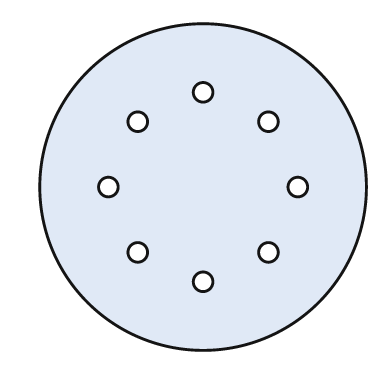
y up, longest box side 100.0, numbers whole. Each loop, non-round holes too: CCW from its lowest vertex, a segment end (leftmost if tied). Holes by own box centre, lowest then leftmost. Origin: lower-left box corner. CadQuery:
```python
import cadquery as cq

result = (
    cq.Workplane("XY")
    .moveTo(50.0, 50.0)
    .circle(50.0)
    .moveTo(50.0, 21.0)
    .circle(3.0)
    .moveTo(30.0, 30.0)
    .circle(3.0)
    .moveTo(70.0, 30.0)
    .circle(3.0)
    .moveTo(21.0, 50.0)
    .circle(3.0)
    .moveTo(79.0, 50.0)
    .circle(3.0)
    .moveTo(30.0, 70.0)
    .circle(3.0)
    .moveTo(70.0, 70.0)
    .circle(3.0)
    .moveTo(50.0, 79.0)
    .circle(3.0)
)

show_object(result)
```